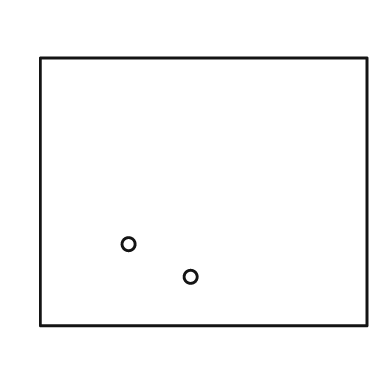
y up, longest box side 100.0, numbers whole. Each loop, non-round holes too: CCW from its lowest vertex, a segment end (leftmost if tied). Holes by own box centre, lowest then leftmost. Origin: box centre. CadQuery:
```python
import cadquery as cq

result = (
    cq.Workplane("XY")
    .moveTo(-50.0, -41.0)
    .lineTo(50.0, -41.0)
    .lineTo(50.0, 41.0)
    .lineTo(-50.0, 41.0)
    .close()
    .moveTo(-4.0, -26.0)
    .circle(2.0)
    .moveTo(-23.0, -16.0)
    .circle(2.0)
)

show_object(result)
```